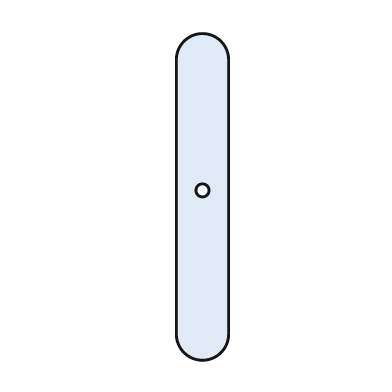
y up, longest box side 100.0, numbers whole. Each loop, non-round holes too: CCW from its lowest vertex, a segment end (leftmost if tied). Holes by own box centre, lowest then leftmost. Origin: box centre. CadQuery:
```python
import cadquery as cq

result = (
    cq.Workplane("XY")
    .moveTo(-8.0, -42.0)
    .threePointArc((0.0, -50.0), (8.0, -42.0))
    .lineTo(8.0, 42.0)
    .threePointArc((0.0, 50.0), (-8.0, 42.0))
    .close()
    .moveTo(0.0, 2.0)
    .circle(2.0)
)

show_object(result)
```